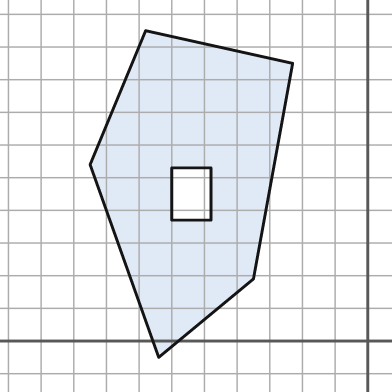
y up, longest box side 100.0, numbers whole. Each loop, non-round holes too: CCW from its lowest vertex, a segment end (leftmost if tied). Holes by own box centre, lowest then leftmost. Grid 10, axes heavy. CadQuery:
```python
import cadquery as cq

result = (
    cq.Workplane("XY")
    .moveTo(-64.0, -5.0)
    .lineTo(-35.0, 19.0)
    .lineTo(-23.0, 85.0)
    .lineTo(-68.0, 95.0)
    .lineTo(-85.0, 54.0)
    .close()
    .moveTo(-60.0, 37.0)
    .lineTo(-48.0, 37.0)
    .lineTo(-48.0, 53.0)
    .lineTo(-60.0, 53.0)
    .close()
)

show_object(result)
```